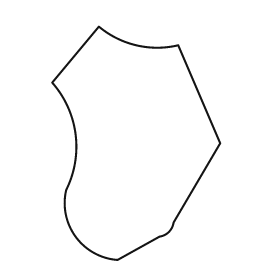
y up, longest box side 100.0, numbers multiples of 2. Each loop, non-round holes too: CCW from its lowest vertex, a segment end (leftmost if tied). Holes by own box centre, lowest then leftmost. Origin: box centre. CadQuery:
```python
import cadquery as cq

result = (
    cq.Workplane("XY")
    .moveTo(-8.0, -50.0)
    .lineTo(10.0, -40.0)
    .threePointArc((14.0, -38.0), (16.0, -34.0))
    .lineTo(36.0, 0.0)
    .lineTo(18.0, 42.0)
    .threePointArc((0.0, 42.0), (-16.0, 50.0))
    .lineTo(-36.0, 26.0)
    .threePointArc((-26.0, 4.0), (-30.0, -20.0))
    .threePointArc((-26.0, -40.0), (-8.0, -50.0))
    .close()
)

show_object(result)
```